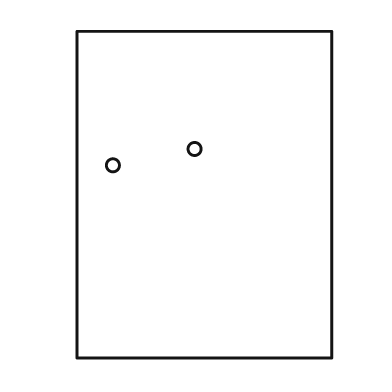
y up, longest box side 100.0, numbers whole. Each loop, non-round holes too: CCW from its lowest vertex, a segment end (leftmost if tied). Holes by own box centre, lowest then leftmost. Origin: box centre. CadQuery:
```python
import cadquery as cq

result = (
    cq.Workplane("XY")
    .moveTo(-39.0, -50.0)
    .lineTo(39.0, -50.0)
    .lineTo(39.0, 50.0)
    .lineTo(-39.0, 50.0)
    .close()
    .moveTo(-28.0, 9.0)
    .circle(2.0)
    .moveTo(-3.0, 14.0)
    .circle(2.0)
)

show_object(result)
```